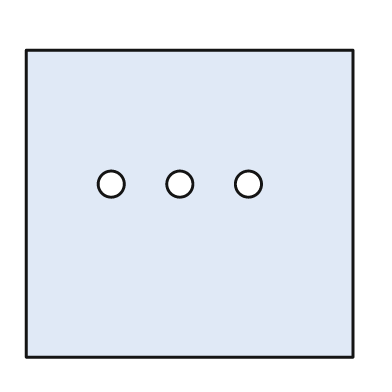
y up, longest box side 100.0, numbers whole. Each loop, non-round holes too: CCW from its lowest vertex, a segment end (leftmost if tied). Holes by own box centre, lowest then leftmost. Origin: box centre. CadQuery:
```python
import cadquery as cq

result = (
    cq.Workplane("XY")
    .moveTo(-50.0, -47.0)
    .lineTo(50.0, -47.0)
    .lineTo(50.0, 47.0)
    .lineTo(-50.0, 47.0)
    .close()
    .moveTo(-24.0, 6.0)
    .circle(4.0)
    .moveTo(-3.0, 6.0)
    .circle(4.0)
    .moveTo(18.0, 6.0)
    .circle(4.0)
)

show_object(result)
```